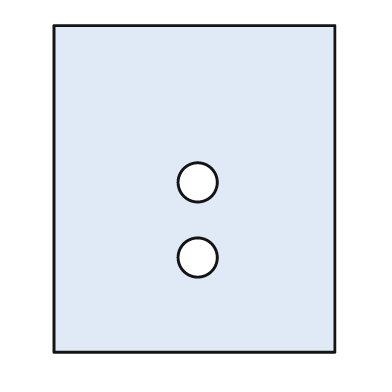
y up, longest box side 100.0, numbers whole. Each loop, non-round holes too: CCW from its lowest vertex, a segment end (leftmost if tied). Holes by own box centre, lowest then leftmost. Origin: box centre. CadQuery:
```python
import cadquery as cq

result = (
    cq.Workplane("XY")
    .moveTo(-43.0, -50.0)
    .lineTo(43.0, -50.0)
    .lineTo(43.0, 50.0)
    .lineTo(-43.0, 50.0)
    .close()
    .moveTo(1.0, -21.0)
    .circle(6.0)
    .moveTo(1.0, 2.0)
    .circle(6.0)
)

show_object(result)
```